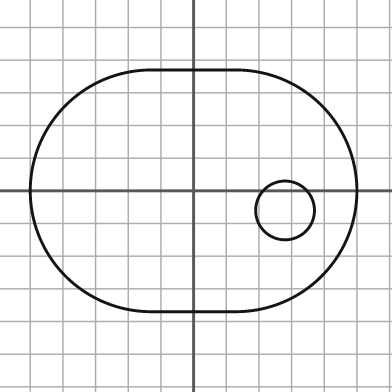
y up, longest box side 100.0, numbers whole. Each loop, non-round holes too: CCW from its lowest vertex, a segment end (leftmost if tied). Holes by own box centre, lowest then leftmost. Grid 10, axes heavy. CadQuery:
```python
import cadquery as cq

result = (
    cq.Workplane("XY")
    .moveTo(-13.0, -37.0)
    .lineTo(13.0, -37.0)
    .threePointArc((50.0, 0.0), (13.0, 37.0))
    .lineTo(-13.0, 37.0)
    .threePointArc((-50.0, 0.0), (-13.0, -37.0))
    .close()
    .moveTo(28.0, -6.0)
    .circle(9.0)
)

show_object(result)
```